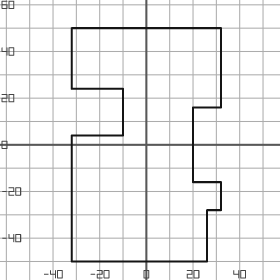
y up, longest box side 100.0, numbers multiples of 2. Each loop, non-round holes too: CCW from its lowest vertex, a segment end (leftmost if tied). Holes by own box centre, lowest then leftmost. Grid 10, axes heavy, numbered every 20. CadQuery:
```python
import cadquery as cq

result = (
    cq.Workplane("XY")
    .moveTo(-32.0, -50.0)
    .lineTo(26.0, -50.0)
    .lineTo(26.0, -28.0)
    .lineTo(32.0, -28.0)
    .lineTo(32.0, -16.0)
    .lineTo(20.0, -16.0)
    .lineTo(20.0, 16.0)
    .lineTo(32.0, 16.0)
    .lineTo(32.0, 50.0)
    .lineTo(-32.0, 50.0)
    .lineTo(-32.0, 24.0)
    .lineTo(-10.0, 24.0)
    .lineTo(-10.0, 4.0)
    .lineTo(-32.0, 4.0)
    .close()
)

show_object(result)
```